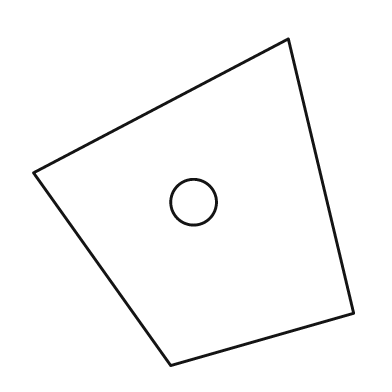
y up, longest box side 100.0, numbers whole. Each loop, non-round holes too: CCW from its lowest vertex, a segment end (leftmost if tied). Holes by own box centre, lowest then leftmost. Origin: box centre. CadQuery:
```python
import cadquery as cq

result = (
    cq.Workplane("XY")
    .moveTo(-7.0, -50.0)
    .lineTo(49.0, -34.0)
    .lineTo(29.0, 50.0)
    .lineTo(-49.0, 9.0)
    .close()
    .moveTo(0.0, 0.0)
    .circle(7.0)
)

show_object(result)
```